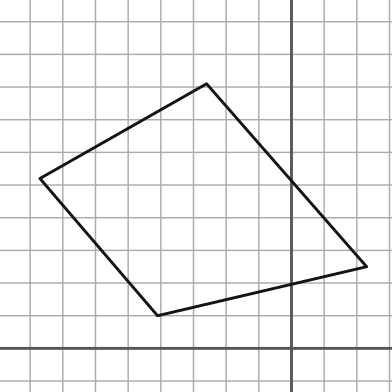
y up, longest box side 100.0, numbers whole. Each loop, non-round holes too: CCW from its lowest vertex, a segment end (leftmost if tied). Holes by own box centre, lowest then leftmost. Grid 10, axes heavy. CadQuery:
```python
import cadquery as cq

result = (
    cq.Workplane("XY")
    .moveTo(-41.0, 10.0)
    .lineTo(23.0, 25.0)
    .lineTo(-26.0, 81.0)
    .lineTo(-77.0, 52.0)
    .close()
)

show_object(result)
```